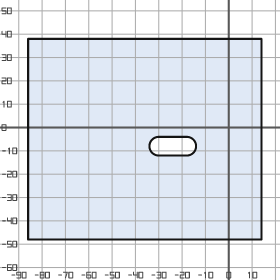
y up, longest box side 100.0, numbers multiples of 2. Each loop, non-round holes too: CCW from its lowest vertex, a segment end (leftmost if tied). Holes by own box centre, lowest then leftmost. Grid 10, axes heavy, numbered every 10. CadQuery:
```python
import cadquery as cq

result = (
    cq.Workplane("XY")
    .moveTo(-86.0, -48.0)
    .lineTo(14.0, -48.0)
    .lineTo(14.0, 38.0)
    .lineTo(-86.0, 38.0)
    .close()
    .moveTo(-30.0, -12.0)
    .lineTo(-18.0, -12.0)
    .threePointArc((-14.0, -8.0), (-18.0, -4.0))
    .lineTo(-30.0, -4.0)
    .threePointArc((-34.0, -8.0), (-30.0, -12.0))
    .close()
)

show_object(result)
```